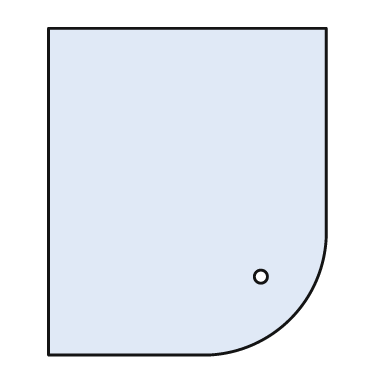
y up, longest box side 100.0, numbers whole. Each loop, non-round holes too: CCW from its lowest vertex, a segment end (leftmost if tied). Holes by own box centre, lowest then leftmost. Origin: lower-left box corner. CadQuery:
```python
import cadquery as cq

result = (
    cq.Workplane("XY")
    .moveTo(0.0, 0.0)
    .lineTo(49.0, 0.0)
    .threePointArc((74.0, 11.0), (85.0, 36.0))
    .lineTo(85.0, 100.0)
    .lineTo(0.0, 100.0)
    .close()
    .moveTo(65.0, 24.0)
    .circle(2.0)
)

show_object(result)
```